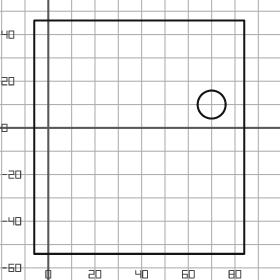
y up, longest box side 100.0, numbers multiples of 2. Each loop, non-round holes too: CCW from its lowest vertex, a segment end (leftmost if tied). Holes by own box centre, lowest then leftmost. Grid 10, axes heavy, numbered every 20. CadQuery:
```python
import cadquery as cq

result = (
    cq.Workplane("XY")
    .moveTo(-6.0, -54.0)
    .lineTo(84.0, -54.0)
    .lineTo(84.0, 46.0)
    .lineTo(-6.0, 46.0)
    .close()
    .moveTo(70.0, 10.0)
    .circle(6.0)
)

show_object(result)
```